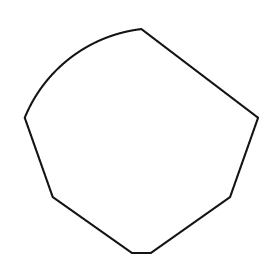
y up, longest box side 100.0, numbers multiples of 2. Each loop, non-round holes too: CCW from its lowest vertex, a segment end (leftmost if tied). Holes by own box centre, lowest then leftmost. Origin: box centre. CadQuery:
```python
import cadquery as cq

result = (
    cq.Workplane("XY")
    .moveTo(-4.0, -48.0)
    .lineTo(4.0, -48.0)
    .lineTo(38.0, -24.0)
    .lineTo(50.0, 10.0)
    .lineTo(0.0, 48.0)
    .threePointArc((-30.0, 36.0), (-50.0, 10.0))
    .lineTo(-38.0, -24.0)
    .close()
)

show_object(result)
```